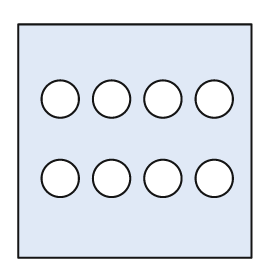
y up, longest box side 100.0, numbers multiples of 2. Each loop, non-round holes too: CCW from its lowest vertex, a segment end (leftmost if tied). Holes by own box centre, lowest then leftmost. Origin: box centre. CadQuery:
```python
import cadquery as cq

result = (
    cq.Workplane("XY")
    .moveTo(-50.0, -50.0)
    .lineTo(50.0, -50.0)
    .lineTo(50.0, 50.0)
    .lineTo(-50.0, 50.0)
    .close()
    .moveTo(-32.0, -16.0)
    .circle(8.0)
    .moveTo(-10.0, -16.0)
    .circle(8.0)
    .moveTo(12.0, -16.0)
    .circle(8.0)
    .moveTo(34.0, -16.0)
    .circle(8.0)
    .moveTo(-32.0, 18.0)
    .circle(8.0)
    .moveTo(-10.0, 18.0)
    .circle(8.0)
    .moveTo(12.0, 18.0)
    .circle(8.0)
    .moveTo(34.0, 18.0)
    .circle(8.0)
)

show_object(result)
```